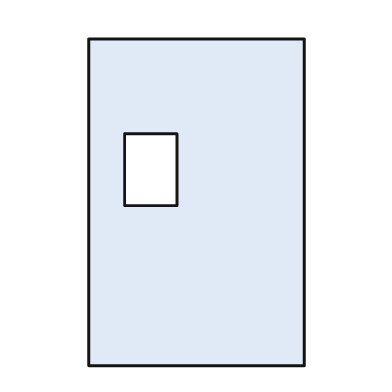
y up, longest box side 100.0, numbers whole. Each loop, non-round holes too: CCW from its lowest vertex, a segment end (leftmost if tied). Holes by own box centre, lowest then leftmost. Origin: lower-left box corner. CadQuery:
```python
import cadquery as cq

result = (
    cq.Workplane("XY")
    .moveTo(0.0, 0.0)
    .lineTo(66.0, 0.0)
    .lineTo(66.0, 100.0)
    .lineTo(0.0, 100.0)
    .close()
    .moveTo(11.0, 49.0)
    .lineTo(27.0, 49.0)
    .lineTo(27.0, 71.0)
    .lineTo(11.0, 71.0)
    .close()
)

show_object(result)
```